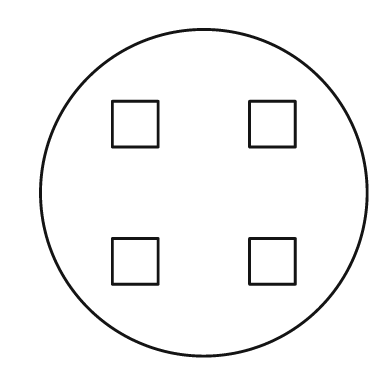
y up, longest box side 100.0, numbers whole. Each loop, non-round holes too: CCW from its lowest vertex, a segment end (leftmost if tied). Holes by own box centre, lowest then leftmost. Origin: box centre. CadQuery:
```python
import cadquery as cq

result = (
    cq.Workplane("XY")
    .moveTo(0.0, 0.0)
    .circle(50.0)
    .moveTo(-28.0, -28.0)
    .lineTo(-14.0, -28.0)
    .lineTo(-14.0, -14.0)
    .lineTo(-28.0, -14.0)
    .close()
    .moveTo(14.0, -28.0)
    .lineTo(28.0, -28.0)
    .lineTo(28.0, -14.0)
    .lineTo(14.0, -14.0)
    .close()
    .moveTo(-28.0, 14.0)
    .lineTo(-14.0, 14.0)
    .lineTo(-14.0, 28.0)
    .lineTo(-28.0, 28.0)
    .close()
    .moveTo(14.0, 14.0)
    .lineTo(28.0, 14.0)
    .lineTo(28.0, 28.0)
    .lineTo(14.0, 28.0)
    .close()
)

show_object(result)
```